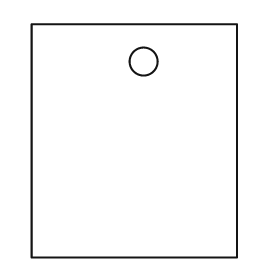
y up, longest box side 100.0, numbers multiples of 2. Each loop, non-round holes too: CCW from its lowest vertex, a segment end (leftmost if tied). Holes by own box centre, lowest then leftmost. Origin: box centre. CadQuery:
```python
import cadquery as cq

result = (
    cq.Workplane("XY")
    .moveTo(-44.0, -50.0)
    .lineTo(44.0, -50.0)
    .lineTo(44.0, 50.0)
    .lineTo(-44.0, 50.0)
    .close()
    .moveTo(4.0, 34.0)
    .circle(6.0)
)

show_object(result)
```